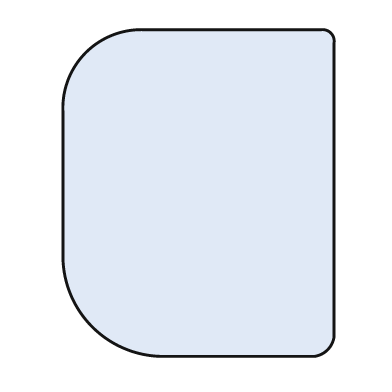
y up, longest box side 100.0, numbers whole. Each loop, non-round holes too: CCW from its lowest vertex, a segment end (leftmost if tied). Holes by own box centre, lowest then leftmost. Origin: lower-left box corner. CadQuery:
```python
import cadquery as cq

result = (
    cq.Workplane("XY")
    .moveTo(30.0, 0.0)
    .lineTo(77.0, 0.0)
    .threePointArc((81.0, 2.0), (83.0, 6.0))
    .lineTo(83.0, 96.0)
    .threePointArc((82.0, 99.0), (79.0, 100.0))
    .lineTo(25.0, 100.0)
    .threePointArc((7.0, 93.0), (0.0, 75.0))
    .lineTo(0.0, 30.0)
    .threePointArc((9.0, 9.0), (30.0, 0.0))
    .close()
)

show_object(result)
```